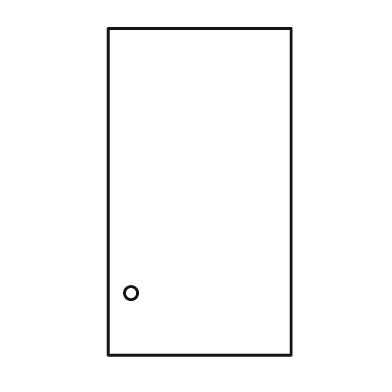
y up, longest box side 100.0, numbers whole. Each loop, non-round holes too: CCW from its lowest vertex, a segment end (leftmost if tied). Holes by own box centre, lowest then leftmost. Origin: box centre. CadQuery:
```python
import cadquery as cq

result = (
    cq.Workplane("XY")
    .moveTo(-28.0, -50.0)
    .lineTo(28.0, -50.0)
    .lineTo(28.0, 50.0)
    .lineTo(-28.0, 50.0)
    .close()
    .moveTo(-21.0, -31.0)
    .circle(2.0)
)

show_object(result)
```